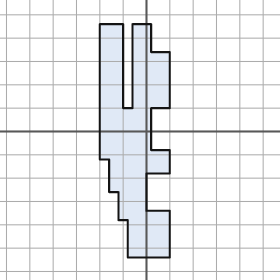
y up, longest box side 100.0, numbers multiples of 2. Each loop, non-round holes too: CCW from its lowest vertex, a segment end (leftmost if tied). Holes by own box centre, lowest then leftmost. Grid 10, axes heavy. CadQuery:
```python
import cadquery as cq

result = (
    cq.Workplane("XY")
    .moveTo(-8.0, -54.0)
    .lineTo(10.0, -54.0)
    .lineTo(10.0, -34.0)
    .lineTo(0.0, -34.0)
    .lineTo(0.0, -18.0)
    .lineTo(10.0, -18.0)
    .lineTo(10.0, -8.0)
    .lineTo(2.0, -8.0)
    .lineTo(2.0, 10.0)
    .lineTo(10.0, 10.0)
    .lineTo(10.0, 34.0)
    .lineTo(2.0, 34.0)
    .lineTo(2.0, 46.0)
    .lineTo(-6.0, 46.0)
    .lineTo(-6.0, 10.0)
    .lineTo(-10.0, 10.0)
    .lineTo(-10.0, 46.0)
    .lineTo(-20.0, 46.0)
    .lineTo(-20.0, -12.0)
    .lineTo(-16.0, -12.0)
    .lineTo(-16.0, -26.0)
    .lineTo(-12.0, -26.0)
    .lineTo(-12.0, -38.0)
    .lineTo(-8.0, -38.0)
    .close()
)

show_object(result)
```